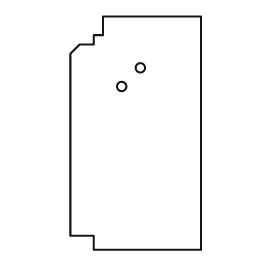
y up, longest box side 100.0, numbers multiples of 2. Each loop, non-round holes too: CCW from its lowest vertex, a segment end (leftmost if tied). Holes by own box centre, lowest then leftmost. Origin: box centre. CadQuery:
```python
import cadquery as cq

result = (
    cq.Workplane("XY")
    .moveTo(-18.0, -50.0)
    .lineTo(28.0, -50.0)
    .lineTo(28.0, 50.0)
    .lineTo(-14.0, 50.0)
    .lineTo(-14.0, 42.0)
    .lineTo(-18.0, 42.0)
    .lineTo(-18.0, 38.0)
    .lineTo(-24.0, 38.0)
    .lineTo(-28.0, 34.0)
    .lineTo(-28.0, -44.0)
    .lineTo(-18.0, -44.0)
    .close()
    .moveTo(-6.0, 20.0)
    .circle(2.0)
    .moveTo(2.0, 28.0)
    .circle(2.0)
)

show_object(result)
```